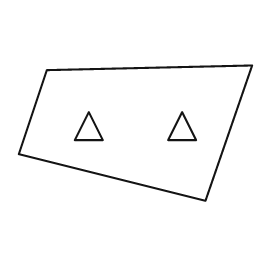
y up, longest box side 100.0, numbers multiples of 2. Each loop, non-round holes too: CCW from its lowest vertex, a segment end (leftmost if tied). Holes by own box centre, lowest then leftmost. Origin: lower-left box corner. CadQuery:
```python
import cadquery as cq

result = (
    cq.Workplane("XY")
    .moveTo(80.0, 0.0)
    .lineTo(100.0, 58.0)
    .lineTo(12.0, 56.0)
    .lineTo(0.0, 20.0)
    .close()
    .moveTo(24.0, 26.0)
    .lineTo(36.0, 26.0)
    .lineTo(30.0, 38.0)
    .close()
    .moveTo(64.0, 26.0)
    .lineTo(76.0, 26.0)
    .lineTo(70.0, 38.0)
    .close()
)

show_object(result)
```